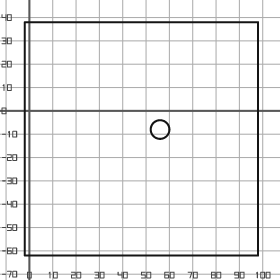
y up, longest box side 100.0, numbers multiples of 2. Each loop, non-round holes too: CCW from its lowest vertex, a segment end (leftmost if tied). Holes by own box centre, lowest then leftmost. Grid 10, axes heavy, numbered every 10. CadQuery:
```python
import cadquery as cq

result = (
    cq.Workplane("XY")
    .moveTo(-2.0, -62.0)
    .lineTo(98.0, -62.0)
    .lineTo(98.0, 38.0)
    .lineTo(-2.0, 38.0)
    .close()
    .moveTo(56.0, -8.0)
    .circle(4.0)
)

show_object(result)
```